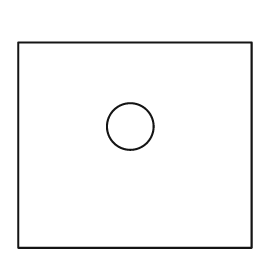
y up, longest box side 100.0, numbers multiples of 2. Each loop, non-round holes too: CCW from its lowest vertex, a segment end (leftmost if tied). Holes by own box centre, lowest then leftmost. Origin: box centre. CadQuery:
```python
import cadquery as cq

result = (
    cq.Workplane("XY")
    .moveTo(-50.0, -44.0)
    .lineTo(50.0, -44.0)
    .lineTo(50.0, 44.0)
    .lineTo(-50.0, 44.0)
    .close()
    .moveTo(-2.0, 8.0)
    .circle(10.0)
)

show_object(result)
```